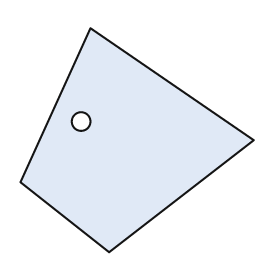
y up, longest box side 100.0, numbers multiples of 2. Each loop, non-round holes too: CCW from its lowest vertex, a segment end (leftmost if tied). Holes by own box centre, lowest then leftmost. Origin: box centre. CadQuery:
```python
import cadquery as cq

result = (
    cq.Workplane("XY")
    .moveTo(-12.0, -48.0)
    .lineTo(50.0, 0.0)
    .lineTo(-20.0, 48.0)
    .lineTo(-50.0, -18.0)
    .close()
    .moveTo(-24.0, 8.0)
    .circle(4.0)
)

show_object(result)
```